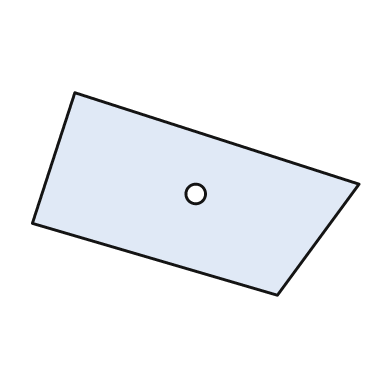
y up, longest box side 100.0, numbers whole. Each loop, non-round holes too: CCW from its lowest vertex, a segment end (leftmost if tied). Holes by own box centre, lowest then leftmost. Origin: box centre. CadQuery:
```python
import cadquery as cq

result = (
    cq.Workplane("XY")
    .moveTo(25.0, -31.0)
    .lineTo(50.0, 3.0)
    .lineTo(-37.0, 31.0)
    .lineTo(-50.0, -9.0)
    .close()
    .moveTo(0.0, 0.0)
    .circle(3.0)
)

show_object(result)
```